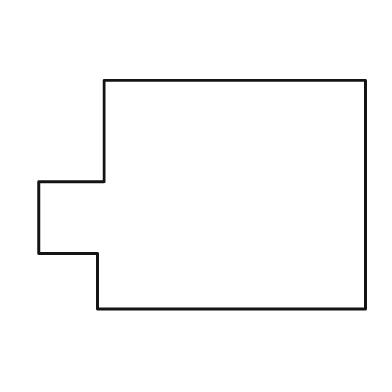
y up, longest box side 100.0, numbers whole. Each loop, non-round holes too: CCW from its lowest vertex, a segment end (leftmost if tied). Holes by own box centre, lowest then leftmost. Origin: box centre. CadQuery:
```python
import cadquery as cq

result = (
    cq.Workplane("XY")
    .moveTo(-32.0, -35.0)
    .lineTo(50.0, -35.0)
    .lineTo(50.0, 35.0)
    .lineTo(-30.0, 35.0)
    .lineTo(-30.0, 4.0)
    .lineTo(-50.0, 4.0)
    .lineTo(-50.0, -18.0)
    .lineTo(-32.0, -18.0)
    .close()
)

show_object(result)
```